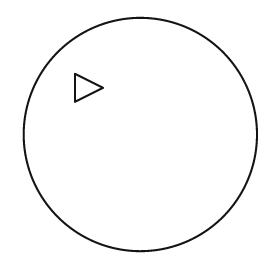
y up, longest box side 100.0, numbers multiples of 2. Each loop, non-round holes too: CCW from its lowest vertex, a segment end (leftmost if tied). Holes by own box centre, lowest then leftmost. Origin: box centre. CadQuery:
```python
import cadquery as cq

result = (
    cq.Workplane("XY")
    .moveTo(0.0, 0.0)
    .circle(50.0)
    .moveTo(-28.0, 14.0)
    .lineTo(-16.0, 20.0)
    .lineTo(-28.0, 26.0)
    .close()
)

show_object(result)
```